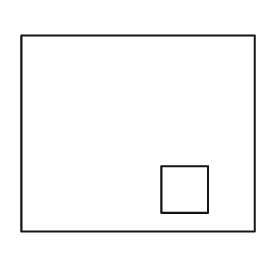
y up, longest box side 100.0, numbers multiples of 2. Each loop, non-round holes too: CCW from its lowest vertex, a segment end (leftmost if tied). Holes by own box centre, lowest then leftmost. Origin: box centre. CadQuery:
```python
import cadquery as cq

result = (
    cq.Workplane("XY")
    .moveTo(-50.0, -42.0)
    .lineTo(50.0, -42.0)
    .lineTo(50.0, 42.0)
    .lineTo(-50.0, 42.0)
    .close()
    .moveTo(10.0, -34.0)
    .lineTo(30.0, -34.0)
    .lineTo(30.0, -14.0)
    .lineTo(10.0, -14.0)
    .close()
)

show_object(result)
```